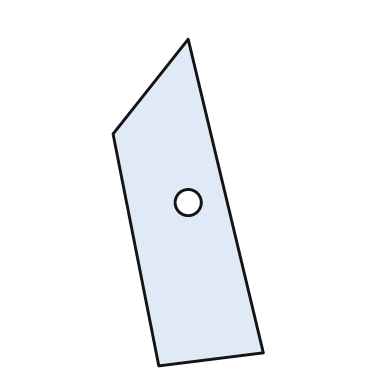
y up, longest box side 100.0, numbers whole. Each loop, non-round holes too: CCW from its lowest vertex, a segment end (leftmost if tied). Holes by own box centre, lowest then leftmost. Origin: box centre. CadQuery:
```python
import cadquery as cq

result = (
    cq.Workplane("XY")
    .moveTo(-9.0, -50.0)
    .lineTo(23.0, -46.0)
    .lineTo(0.0, 50.0)
    .lineTo(-23.0, 21.0)
    .close()
    .moveTo(0.0, 0.0)
    .circle(4.0)
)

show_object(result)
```